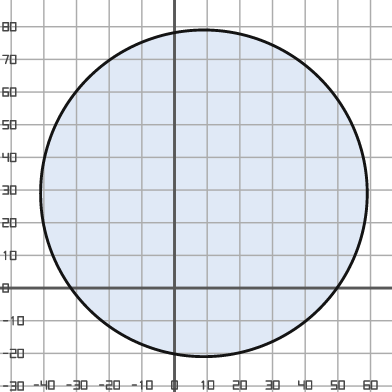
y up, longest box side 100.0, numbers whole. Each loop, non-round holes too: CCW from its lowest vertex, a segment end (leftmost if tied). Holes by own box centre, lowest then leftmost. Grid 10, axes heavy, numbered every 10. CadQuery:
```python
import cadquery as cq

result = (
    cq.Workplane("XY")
    .moveTo(9.0, 29.0)
    .circle(50.0)
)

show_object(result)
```